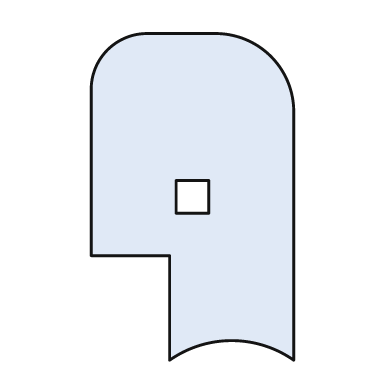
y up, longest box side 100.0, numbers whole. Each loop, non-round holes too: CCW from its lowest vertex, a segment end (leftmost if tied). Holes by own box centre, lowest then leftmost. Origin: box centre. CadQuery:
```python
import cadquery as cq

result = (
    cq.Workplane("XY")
    .moveTo(-7.0, -50.0)
    .threePointArc((12.0, -44.0), (31.0, -50.0))
    .lineTo(31.0, 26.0)
    .threePointArc((24.0, 43.0), (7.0, 50.0))
    .lineTo(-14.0, 50.0)
    .threePointArc((-26.0, 45.0), (-31.0, 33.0))
    .lineTo(-31.0, -18.0)
    .lineTo(-7.0, -18.0)
    .close()
    .moveTo(-5.0, -5.0)
    .lineTo(5.0, -5.0)
    .lineTo(5.0, 5.0)
    .lineTo(-5.0, 5.0)
    .close()
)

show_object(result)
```